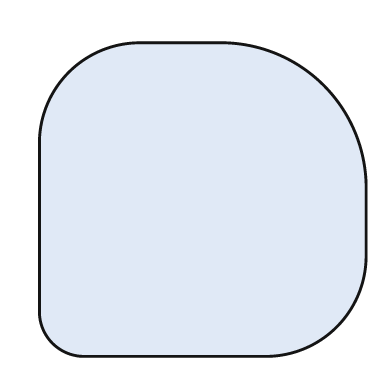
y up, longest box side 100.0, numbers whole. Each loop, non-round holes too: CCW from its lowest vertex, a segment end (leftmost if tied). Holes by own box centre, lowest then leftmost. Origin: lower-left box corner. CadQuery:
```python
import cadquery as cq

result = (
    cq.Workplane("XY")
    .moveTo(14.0, 0.0)
    .lineTo(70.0, 0.0)
    .threePointArc((91.0, 9.0), (100.0, 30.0))
    .lineTo(100.0, 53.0)
    .threePointArc((87.0, 83.0), (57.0, 96.0))
    .lineTo(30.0, 96.0)
    .threePointArc((9.0, 87.0), (0.0, 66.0))
    .lineTo(0.0, 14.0)
    .threePointArc((4.0, 4.0), (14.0, 0.0))
    .close()
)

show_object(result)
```